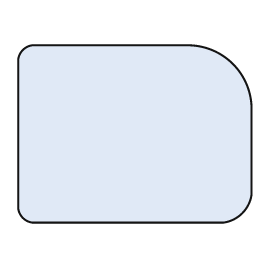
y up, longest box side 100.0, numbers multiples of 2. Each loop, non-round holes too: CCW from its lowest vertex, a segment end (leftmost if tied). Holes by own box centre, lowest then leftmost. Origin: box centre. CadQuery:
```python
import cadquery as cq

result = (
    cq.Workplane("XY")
    .moveTo(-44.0, -38.0)
    .lineTo(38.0, -38.0)
    .threePointArc((46.0, -34.0), (50.0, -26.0))
    .lineTo(50.0, 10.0)
    .threePointArc((42.0, 30.0), (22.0, 38.0))
    .lineTo(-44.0, 38.0)
    .threePointArc((-48.0, 36.0), (-50.0, 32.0))
    .lineTo(-50.0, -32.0)
    .threePointArc((-48.0, -36.0), (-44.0, -38.0))
    .close()
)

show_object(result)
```